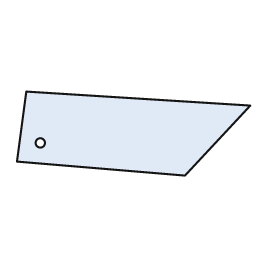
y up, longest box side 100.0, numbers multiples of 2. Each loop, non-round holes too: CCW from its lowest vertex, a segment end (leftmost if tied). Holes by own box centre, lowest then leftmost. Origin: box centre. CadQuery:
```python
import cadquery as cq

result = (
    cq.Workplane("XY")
    .moveTo(22.0, -18.0)
    .lineTo(50.0, 12.0)
    .lineTo(-46.0, 18.0)
    .lineTo(-50.0, -12.0)
    .close()
    .moveTo(-40.0, -4.0)
    .circle(2.0)
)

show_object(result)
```